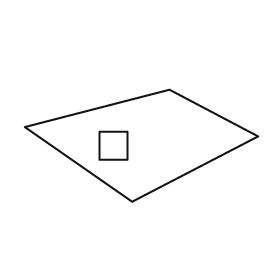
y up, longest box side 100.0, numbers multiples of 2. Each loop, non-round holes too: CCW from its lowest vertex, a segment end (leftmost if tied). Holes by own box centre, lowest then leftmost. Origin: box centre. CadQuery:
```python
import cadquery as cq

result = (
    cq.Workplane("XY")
    .moveTo(-4.0, -24.0)
    .lineTo(50.0, 4.0)
    .lineTo(12.0, 24.0)
    .lineTo(-50.0, 8.0)
    .close()
    .moveTo(-18.0, -6.0)
    .lineTo(-6.0, -6.0)
    .lineTo(-6.0, 6.0)
    .lineTo(-18.0, 6.0)
    .close()
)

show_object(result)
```